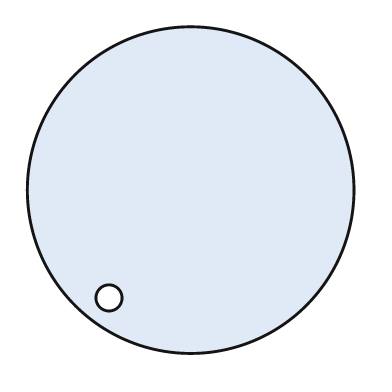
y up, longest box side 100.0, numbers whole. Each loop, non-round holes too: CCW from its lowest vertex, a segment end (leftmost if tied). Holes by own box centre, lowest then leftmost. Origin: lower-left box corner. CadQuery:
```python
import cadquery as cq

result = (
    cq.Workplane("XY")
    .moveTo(50.0, 50.0)
    .circle(50.0)
    .moveTo(25.0, 17.0)
    .circle(4.0)
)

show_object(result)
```